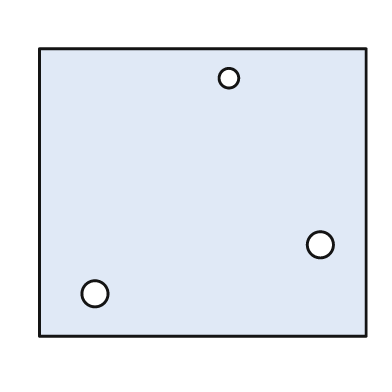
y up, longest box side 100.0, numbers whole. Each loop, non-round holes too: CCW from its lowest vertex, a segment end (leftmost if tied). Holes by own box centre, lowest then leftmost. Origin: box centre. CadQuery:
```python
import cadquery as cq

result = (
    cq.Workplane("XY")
    .moveTo(-50.0, -44.0)
    .lineTo(50.0, -44.0)
    .lineTo(50.0, 44.0)
    .lineTo(-50.0, 44.0)
    .close()
    .moveTo(-33.0, -31.0)
    .circle(4.0)
    .moveTo(36.0, -16.0)
    .circle(4.0)
    .moveTo(8.0, 35.0)
    .circle(3.0)
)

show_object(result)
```